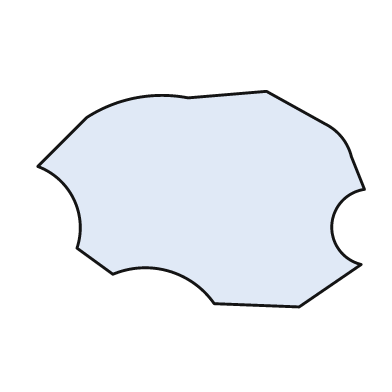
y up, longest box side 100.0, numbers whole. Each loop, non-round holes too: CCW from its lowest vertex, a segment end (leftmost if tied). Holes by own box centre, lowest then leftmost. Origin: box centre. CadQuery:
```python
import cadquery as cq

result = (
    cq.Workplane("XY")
    .moveTo(30.0, -33.0)
    .lineTo(49.0, -20.0)
    .threePointArc((40.0, -8.0), (50.0, 3.0))
    .lineTo(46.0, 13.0)
    .threePointArc((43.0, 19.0), (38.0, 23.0))
    .lineTo(20.0, 33.0)
    .lineTo(-4.0, 31.0)
    .threePointArc((-20.0, 31.0), (-35.0, 25.0))
    .lineTo(-50.0, 10.0)
    .threePointArc((-39.0, 0.0), (-38.0, -15.0))
    .lineTo(-27.0, -23.0)
    .threePointArc((-10.0, -22.0), (4.0, -32.0))
    .close()
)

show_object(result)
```